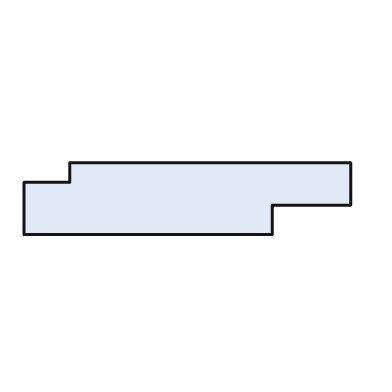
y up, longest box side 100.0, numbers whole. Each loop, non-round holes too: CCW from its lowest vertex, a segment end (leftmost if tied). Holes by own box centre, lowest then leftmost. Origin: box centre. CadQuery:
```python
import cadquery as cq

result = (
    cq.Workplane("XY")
    .moveTo(-50.0, -11.0)
    .lineTo(26.0, -11.0)
    .lineTo(26.0, -2.0)
    .lineTo(50.0, -2.0)
    .lineTo(50.0, 11.0)
    .lineTo(-36.0, 11.0)
    .lineTo(-36.0, 5.0)
    .lineTo(-50.0, 5.0)
    .close()
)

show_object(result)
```